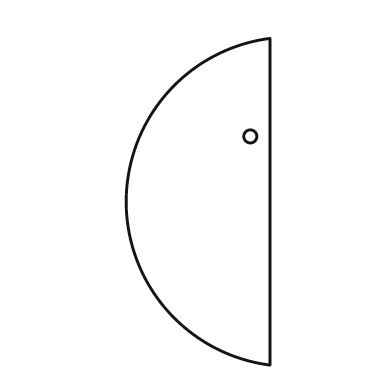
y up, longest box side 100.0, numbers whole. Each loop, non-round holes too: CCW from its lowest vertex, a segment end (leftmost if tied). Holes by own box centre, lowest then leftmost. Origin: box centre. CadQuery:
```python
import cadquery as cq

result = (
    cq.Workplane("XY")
    .moveTo(22.0, -50.0)
    .lineTo(22.0, 50.0)
    .threePointArc((-22.0, 0.0), (22.0, -50.0))
    .close()
    .moveTo(16.0, 20.0)
    .circle(2.0)
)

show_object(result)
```